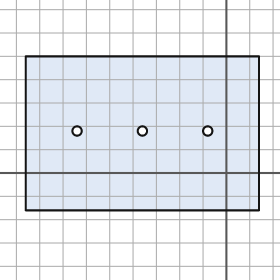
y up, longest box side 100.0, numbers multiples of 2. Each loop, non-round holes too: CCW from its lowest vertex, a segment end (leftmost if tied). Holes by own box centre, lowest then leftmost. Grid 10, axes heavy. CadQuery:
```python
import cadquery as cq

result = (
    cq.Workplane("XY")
    .moveTo(-86.0, -16.0)
    .lineTo(14.0, -16.0)
    .lineTo(14.0, 50.0)
    .lineTo(-86.0, 50.0)
    .close()
    .moveTo(-64.0, 18.0)
    .circle(2.0)
    .moveTo(-36.0, 18.0)
    .circle(2.0)
    .moveTo(-8.0, 18.0)
    .circle(2.0)
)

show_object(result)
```